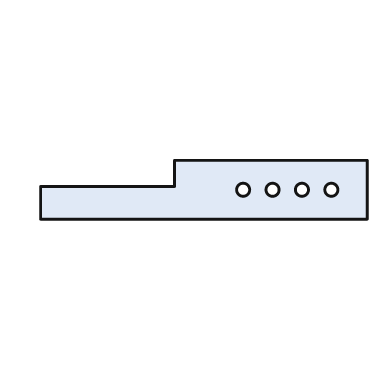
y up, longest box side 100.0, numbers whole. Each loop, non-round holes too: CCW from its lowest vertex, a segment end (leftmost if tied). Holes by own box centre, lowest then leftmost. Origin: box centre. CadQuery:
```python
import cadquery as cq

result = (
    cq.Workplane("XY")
    .moveTo(-50.0, -9.0)
    .lineTo(50.0, -9.0)
    .lineTo(50.0, 9.0)
    .lineTo(-9.0, 9.0)
    .lineTo(-9.0, 1.0)
    .lineTo(-50.0, 1.0)
    .close()
    .moveTo(12.0, 0.0)
    .circle(2.0)
    .moveTo(21.0, 0.0)
    .circle(2.0)
    .moveTo(30.0, 0.0)
    .circle(2.0)
    .moveTo(39.0, 0.0)
    .circle(2.0)
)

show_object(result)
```